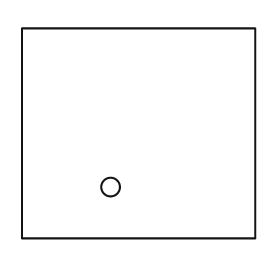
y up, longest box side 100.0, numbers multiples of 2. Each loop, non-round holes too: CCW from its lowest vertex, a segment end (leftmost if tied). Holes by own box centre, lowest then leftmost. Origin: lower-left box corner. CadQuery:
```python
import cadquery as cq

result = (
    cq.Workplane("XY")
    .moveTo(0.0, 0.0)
    .lineTo(100.0, 0.0)
    .lineTo(100.0, 90.0)
    .lineTo(0.0, 90.0)
    .close()
    .moveTo(38.0, 22.0)
    .circle(4.0)
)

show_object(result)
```